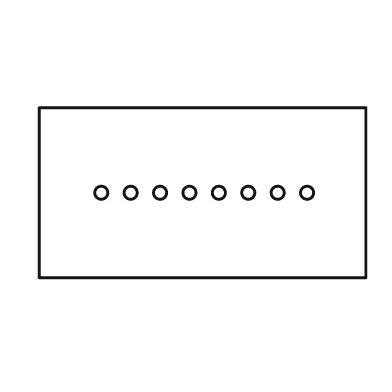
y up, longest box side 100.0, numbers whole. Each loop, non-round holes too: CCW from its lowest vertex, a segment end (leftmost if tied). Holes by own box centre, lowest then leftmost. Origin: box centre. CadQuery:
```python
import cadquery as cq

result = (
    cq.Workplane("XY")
    .moveTo(-50.0, -26.0)
    .lineTo(50.0, -26.0)
    .lineTo(50.0, 26.0)
    .lineTo(-50.0, 26.0)
    .close()
    .moveTo(-31.0, 0.0)
    .circle(2.0)
    .moveTo(-22.0, 0.0)
    .circle(2.0)
    .moveTo(-13.0, 0.0)
    .circle(2.0)
    .moveTo(-4.0, 0.0)
    .circle(2.0)
    .moveTo(5.0, 0.0)
    .circle(2.0)
    .moveTo(14.0, 0.0)
    .circle(2.0)
    .moveTo(23.0, 0.0)
    .circle(2.0)
    .moveTo(32.0, 0.0)
    .circle(2.0)
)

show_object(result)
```